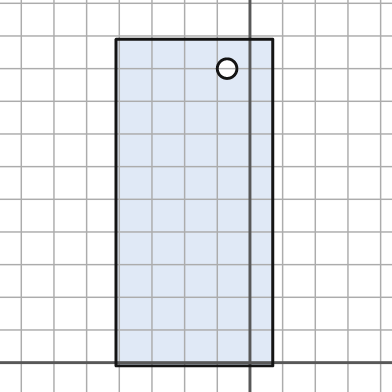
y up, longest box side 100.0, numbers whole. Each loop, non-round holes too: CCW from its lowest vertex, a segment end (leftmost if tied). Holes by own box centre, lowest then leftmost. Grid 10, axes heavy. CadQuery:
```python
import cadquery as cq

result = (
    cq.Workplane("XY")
    .moveTo(-41.0, -1.0)
    .lineTo(7.0, -1.0)
    .lineTo(7.0, 99.0)
    .lineTo(-41.0, 99.0)
    .close()
    .moveTo(-7.0, 90.0)
    .circle(3.0)
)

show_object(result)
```